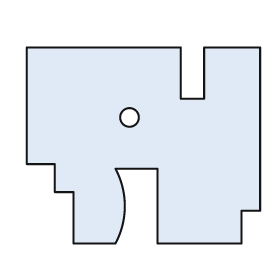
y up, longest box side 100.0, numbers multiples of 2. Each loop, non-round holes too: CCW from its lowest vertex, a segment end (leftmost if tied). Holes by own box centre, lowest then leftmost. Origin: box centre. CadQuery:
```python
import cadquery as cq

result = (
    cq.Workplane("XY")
    .moveTo(-30.0, -42.0)
    .lineTo(-12.0, -42.0)
    .threePointArc((-8.0, -26.0), (-12.0, -10.0))
    .lineTo(6.0, -10.0)
    .lineTo(6.0, -42.0)
    .lineTo(42.0, -42.0)
    .lineTo(42.0, -28.0)
    .lineTo(50.0, -28.0)
    .lineTo(50.0, 42.0)
    .lineTo(26.0, 42.0)
    .lineTo(26.0, 20.0)
    .lineTo(16.0, 20.0)
    .lineTo(16.0, 42.0)
    .lineTo(-50.0, 42.0)
    .lineTo(-50.0, -8.0)
    .lineTo(-38.0, -8.0)
    .lineTo(-38.0, -20.0)
    .lineTo(-30.0, -20.0)
    .close()
    .moveTo(-6.0, 12.0)
    .circle(4.0)
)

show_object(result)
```